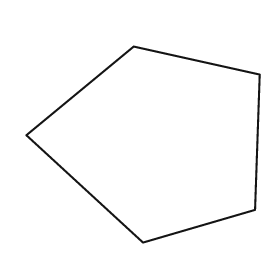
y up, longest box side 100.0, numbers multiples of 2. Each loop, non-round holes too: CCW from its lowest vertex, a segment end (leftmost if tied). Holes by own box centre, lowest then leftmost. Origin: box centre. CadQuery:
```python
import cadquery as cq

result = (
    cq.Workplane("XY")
    .moveTo(0.0, -42.0)
    .lineTo(48.0, -28.0)
    .lineTo(50.0, 30.0)
    .lineTo(-4.0, 42.0)
    .lineTo(-50.0, 4.0)
    .close()
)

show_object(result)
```